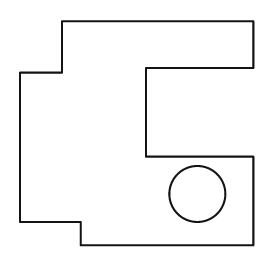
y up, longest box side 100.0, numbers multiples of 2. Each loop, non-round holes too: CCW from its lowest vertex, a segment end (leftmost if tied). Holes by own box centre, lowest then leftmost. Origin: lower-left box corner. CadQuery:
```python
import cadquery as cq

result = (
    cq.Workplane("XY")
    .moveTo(26.0, 0.0)
    .lineTo(100.0, 0.0)
    .lineTo(100.0, 38.0)
    .lineTo(54.0, 38.0)
    .lineTo(54.0, 76.0)
    .lineTo(100.0, 76.0)
    .lineTo(100.0, 96.0)
    .lineTo(18.0, 96.0)
    .lineTo(18.0, 74.0)
    .lineTo(0.0, 74.0)
    .lineTo(0.0, 10.0)
    .lineTo(26.0, 10.0)
    .close()
    .moveTo(76.0, 22.0)
    .circle(12.0)
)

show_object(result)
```